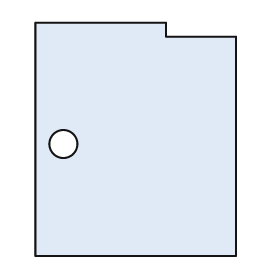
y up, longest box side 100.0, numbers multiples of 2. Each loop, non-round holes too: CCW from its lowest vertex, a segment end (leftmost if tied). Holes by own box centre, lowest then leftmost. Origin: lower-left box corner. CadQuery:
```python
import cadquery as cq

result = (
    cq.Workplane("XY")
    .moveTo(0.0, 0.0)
    .lineTo(86.0, 0.0)
    .lineTo(86.0, 94.0)
    .lineTo(56.0, 94.0)
    .lineTo(56.0, 100.0)
    .lineTo(0.0, 100.0)
    .close()
    .moveTo(12.0, 48.0)
    .circle(6.0)
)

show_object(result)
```